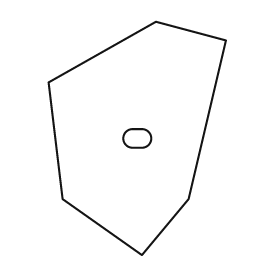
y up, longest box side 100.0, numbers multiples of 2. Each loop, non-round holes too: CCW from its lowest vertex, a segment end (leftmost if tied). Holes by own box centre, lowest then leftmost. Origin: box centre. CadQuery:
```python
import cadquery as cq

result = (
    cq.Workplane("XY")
    .moveTo(2.0, -50.0)
    .lineTo(22.0, -26.0)
    .lineTo(38.0, 42.0)
    .lineTo(8.0, 50.0)
    .lineTo(-38.0, 24.0)
    .lineTo(-32.0, -26.0)
    .close()
    .moveTo(-2.0, -4.0)
    .lineTo(2.0, -4.0)
    .threePointArc((6.0, 0.0), (2.0, 4.0))
    .lineTo(-2.0, 4.0)
    .threePointArc((-6.0, 0.0), (-2.0, -4.0))
    .close()
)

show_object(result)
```